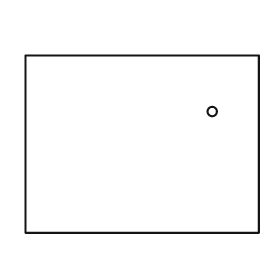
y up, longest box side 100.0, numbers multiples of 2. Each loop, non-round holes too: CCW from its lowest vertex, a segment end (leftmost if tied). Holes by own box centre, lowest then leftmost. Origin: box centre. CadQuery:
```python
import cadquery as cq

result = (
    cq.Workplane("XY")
    .moveTo(-50.0, -38.0)
    .lineTo(50.0, -38.0)
    .lineTo(50.0, 38.0)
    .lineTo(-50.0, 38.0)
    .close()
    .moveTo(30.0, 14.0)
    .circle(2.0)
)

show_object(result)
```